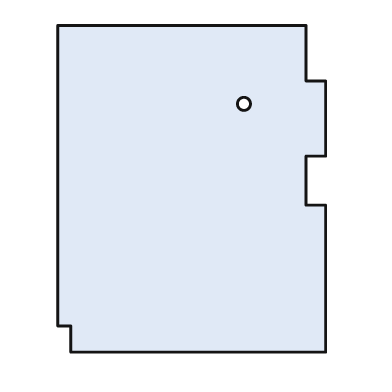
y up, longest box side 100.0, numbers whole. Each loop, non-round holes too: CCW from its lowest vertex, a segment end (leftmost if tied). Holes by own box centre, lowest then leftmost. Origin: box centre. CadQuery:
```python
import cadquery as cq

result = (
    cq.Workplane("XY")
    .moveTo(-37.0, -50.0)
    .lineTo(41.0, -50.0)
    .lineTo(41.0, -5.0)
    .lineTo(35.0, -5.0)
    .lineTo(35.0, 10.0)
    .lineTo(41.0, 10.0)
    .lineTo(41.0, 33.0)
    .lineTo(35.0, 33.0)
    .lineTo(35.0, 50.0)
    .lineTo(-41.0, 50.0)
    .lineTo(-41.0, -42.0)
    .lineTo(-37.0, -42.0)
    .close()
    .moveTo(16.0, 26.0)
    .circle(2.0)
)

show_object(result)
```